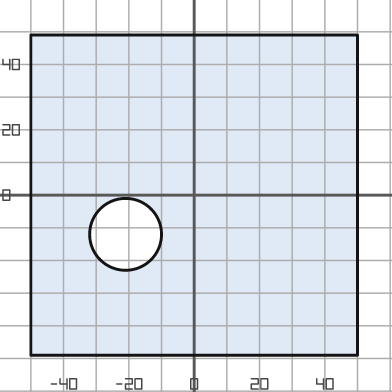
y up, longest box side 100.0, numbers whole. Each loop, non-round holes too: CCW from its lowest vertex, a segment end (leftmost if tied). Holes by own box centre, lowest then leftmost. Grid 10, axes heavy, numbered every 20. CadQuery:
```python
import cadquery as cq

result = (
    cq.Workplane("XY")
    .moveTo(-50.0, -49.0)
    .lineTo(50.0, -49.0)
    .lineTo(50.0, 49.0)
    .lineTo(-50.0, 49.0)
    .close()
    .moveTo(-21.0, -12.0)
    .circle(11.0)
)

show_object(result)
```